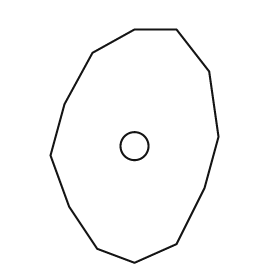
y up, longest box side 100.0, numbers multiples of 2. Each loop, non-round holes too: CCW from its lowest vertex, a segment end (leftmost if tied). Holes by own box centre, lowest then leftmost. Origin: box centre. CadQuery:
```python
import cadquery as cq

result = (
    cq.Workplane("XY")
    .moveTo(0.0, -50.0)
    .lineTo(18.0, -42.0)
    .lineTo(30.0, -18.0)
    .lineTo(36.0, 4.0)
    .lineTo(32.0, 32.0)
    .lineTo(18.0, 50.0)
    .lineTo(0.0, 50.0)
    .lineTo(-18.0, 40.0)
    .lineTo(-30.0, 18.0)
    .lineTo(-36.0, -4.0)
    .lineTo(-28.0, -26.0)
    .lineTo(-16.0, -44.0)
    .close()
    .moveTo(0.0, 0.0)
    .circle(6.0)
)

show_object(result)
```